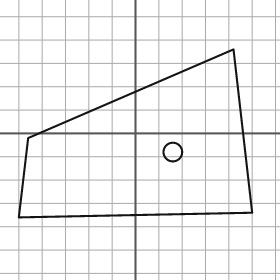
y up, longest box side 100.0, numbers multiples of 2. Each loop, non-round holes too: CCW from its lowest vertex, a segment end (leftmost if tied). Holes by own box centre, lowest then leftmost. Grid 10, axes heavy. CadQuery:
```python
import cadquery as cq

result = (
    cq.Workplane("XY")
    .moveTo(-50.0, -36.0)
    .lineTo(50.0, -34.0)
    .lineTo(42.0, 36.0)
    .lineTo(-46.0, -2.0)
    .close()
    .moveTo(16.0, -8.0)
    .circle(4.0)
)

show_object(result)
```